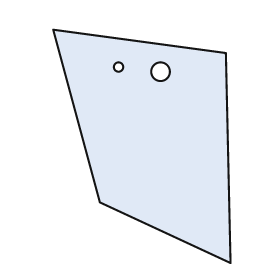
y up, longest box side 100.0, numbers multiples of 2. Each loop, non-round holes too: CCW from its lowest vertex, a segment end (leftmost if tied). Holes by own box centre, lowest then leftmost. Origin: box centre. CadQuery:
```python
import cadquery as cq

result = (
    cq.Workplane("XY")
    .moveTo(38.0, -50.0)
    .lineTo(36.0, 40.0)
    .lineTo(-38.0, 50.0)
    .lineTo(-18.0, -24.0)
    .close()
    .moveTo(8.0, 32.0)
    .circle(4.0)
    .moveTo(-10.0, 34.0)
    .circle(2.0)
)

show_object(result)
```